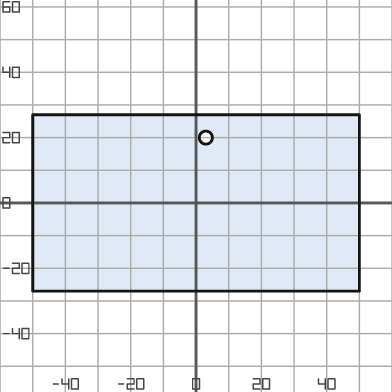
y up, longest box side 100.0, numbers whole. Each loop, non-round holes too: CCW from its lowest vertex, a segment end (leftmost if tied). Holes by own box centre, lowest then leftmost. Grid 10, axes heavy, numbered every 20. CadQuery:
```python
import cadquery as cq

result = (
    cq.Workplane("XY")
    .moveTo(-50.0, -27.0)
    .lineTo(50.0, -27.0)
    .lineTo(50.0, 27.0)
    .lineTo(-50.0, 27.0)
    .close()
    .moveTo(3.0, 20.0)
    .circle(2.0)
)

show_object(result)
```